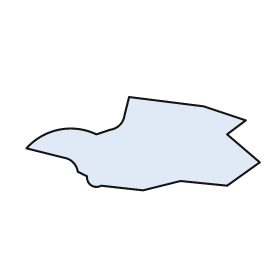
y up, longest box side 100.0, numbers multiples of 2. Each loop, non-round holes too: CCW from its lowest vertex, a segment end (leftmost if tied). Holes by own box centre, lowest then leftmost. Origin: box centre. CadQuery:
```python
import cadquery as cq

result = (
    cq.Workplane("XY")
    .moveTo(0.0, -20.0)
    .lineTo(16.0, -16.0)
    .lineTo(36.0, -18.0)
    .lineTo(50.0, -8.0)
    .lineTo(36.0, 4.0)
    .lineTo(44.0, 10.0)
    .lineTo(26.0, 16.0)
    .lineTo(-6.0, 20.0)
    .lineTo(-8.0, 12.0)
    .threePointArc((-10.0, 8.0), (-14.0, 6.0))
    .lineTo(-20.0, 4.0)
    .threePointArc((-36.0, 6.0), (-50.0, -2.0))
    .lineTo(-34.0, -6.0)
    .threePointArc((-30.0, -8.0), (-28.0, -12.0))
    .lineTo(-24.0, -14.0)
    .threePointArc((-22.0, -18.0), (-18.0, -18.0))
    .close()
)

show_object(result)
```